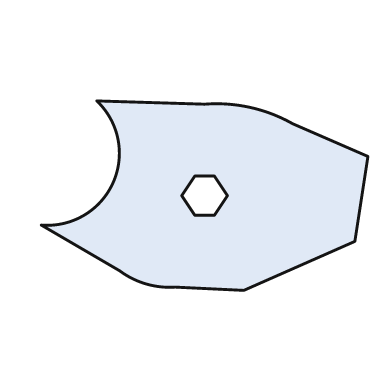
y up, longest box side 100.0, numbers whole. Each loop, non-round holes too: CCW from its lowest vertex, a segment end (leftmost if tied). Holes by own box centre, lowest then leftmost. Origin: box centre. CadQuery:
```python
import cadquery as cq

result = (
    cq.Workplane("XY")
    .moveTo(12.0, -29.0)
    .lineTo(46.0, -14.0)
    .lineTo(50.0, 12.0)
    .lineTo(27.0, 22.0)
    .threePointArc((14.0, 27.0), (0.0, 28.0))
    .lineTo(-33.0, 29.0)
    .threePointArc((-28.0, 4.0), (-50.0, -9.0))
    .lineTo(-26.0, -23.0)
    .threePointArc((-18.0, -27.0), (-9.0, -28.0))
    .close()
    .moveTo(-3.0, -6.0)
    .lineTo(3.0, -6.0)
    .lineTo(7.0, 0.0)
    .lineTo(3.0, 6.0)
    .lineTo(-3.0, 6.0)
    .lineTo(-7.0, 0.0)
    .close()
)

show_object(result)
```